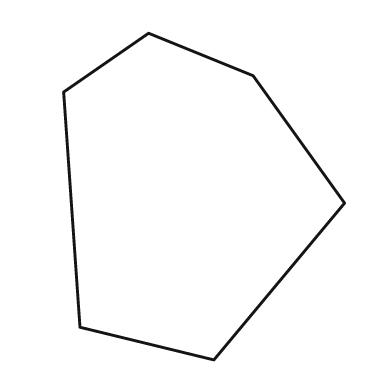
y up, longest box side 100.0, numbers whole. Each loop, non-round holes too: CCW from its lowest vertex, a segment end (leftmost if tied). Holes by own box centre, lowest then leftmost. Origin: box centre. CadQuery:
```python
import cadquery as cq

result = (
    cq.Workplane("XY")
    .moveTo(3.0, -50.0)
    .lineTo(43.0, -2.0)
    .lineTo(15.0, 37.0)
    .lineTo(-17.0, 50.0)
    .lineTo(-43.0, 32.0)
    .lineTo(-38.0, -40.0)
    .close()
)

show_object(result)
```